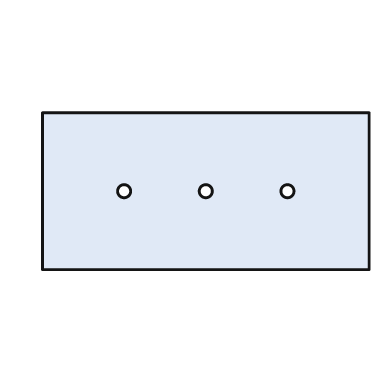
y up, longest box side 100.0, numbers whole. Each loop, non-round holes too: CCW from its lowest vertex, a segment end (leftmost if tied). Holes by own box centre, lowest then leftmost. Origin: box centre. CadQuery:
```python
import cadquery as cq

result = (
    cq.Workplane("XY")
    .moveTo(-50.0, -24.0)
    .lineTo(50.0, -24.0)
    .lineTo(50.0, 24.0)
    .lineTo(-50.0, 24.0)
    .close()
    .moveTo(-25.0, 0.0)
    .circle(2.0)
    .moveTo(0.0, 0.0)
    .circle(2.0)
    .moveTo(25.0, 0.0)
    .circle(2.0)
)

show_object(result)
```